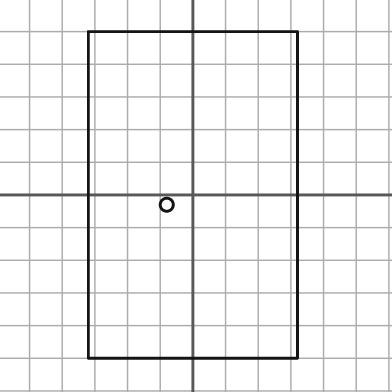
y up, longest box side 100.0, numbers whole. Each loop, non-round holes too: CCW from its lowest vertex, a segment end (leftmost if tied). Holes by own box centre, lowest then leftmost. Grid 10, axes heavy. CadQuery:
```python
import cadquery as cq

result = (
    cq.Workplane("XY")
    .moveTo(-32.0, -50.0)
    .lineTo(32.0, -50.0)
    .lineTo(32.0, 50.0)
    .lineTo(-32.0, 50.0)
    .close()
    .moveTo(-8.0, -3.0)
    .circle(2.0)
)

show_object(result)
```